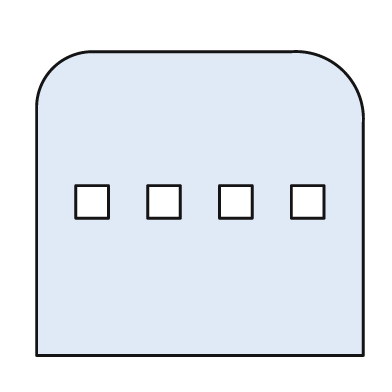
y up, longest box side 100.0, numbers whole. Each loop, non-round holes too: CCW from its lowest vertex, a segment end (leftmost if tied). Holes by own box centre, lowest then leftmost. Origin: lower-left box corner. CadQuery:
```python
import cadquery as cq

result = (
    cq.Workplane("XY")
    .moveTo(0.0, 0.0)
    .lineTo(100.0, 0.0)
    .lineTo(100.0, 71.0)
    .threePointArc((94.0, 87.0), (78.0, 93.0))
    .lineTo(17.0, 93.0)
    .threePointArc((5.0, 88.0), (0.0, 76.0))
    .close()
    .moveTo(12.0, 42.0)
    .lineTo(22.0, 42.0)
    .lineTo(22.0, 52.0)
    .lineTo(12.0, 52.0)
    .close()
    .moveTo(34.0, 42.0)
    .lineTo(44.0, 42.0)
    .lineTo(44.0, 52.0)
    .lineTo(34.0, 52.0)
    .close()
    .moveTo(56.0, 42.0)
    .lineTo(66.0, 42.0)
    .lineTo(66.0, 52.0)
    .lineTo(56.0, 52.0)
    .close()
    .moveTo(78.0, 42.0)
    .lineTo(88.0, 42.0)
    .lineTo(88.0, 52.0)
    .lineTo(78.0, 52.0)
    .close()
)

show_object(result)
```